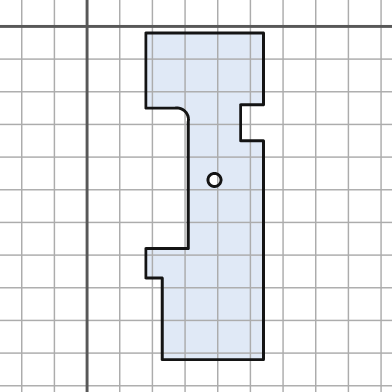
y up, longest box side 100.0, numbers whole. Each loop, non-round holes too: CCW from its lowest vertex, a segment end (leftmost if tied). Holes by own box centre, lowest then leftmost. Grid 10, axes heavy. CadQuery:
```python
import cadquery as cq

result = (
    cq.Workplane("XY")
    .moveTo(23.0, -102.0)
    .lineTo(54.0, -102.0)
    .lineTo(54.0, -35.0)
    .lineTo(47.0, -35.0)
    .lineTo(47.0, -24.0)
    .lineTo(54.0, -24.0)
    .lineTo(54.0, -2.0)
    .lineTo(18.0, -2.0)
    .lineTo(18.0, -25.0)
    .lineTo(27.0, -25.0)
    .threePointArc((30.0, -26.0), (31.0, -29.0))
    .lineTo(31.0, -68.0)
    .lineTo(18.0, -68.0)
    .lineTo(18.0, -77.0)
    .lineTo(23.0, -77.0)
    .close()
    .moveTo(39.0, -47.0)
    .circle(2.0)
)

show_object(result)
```